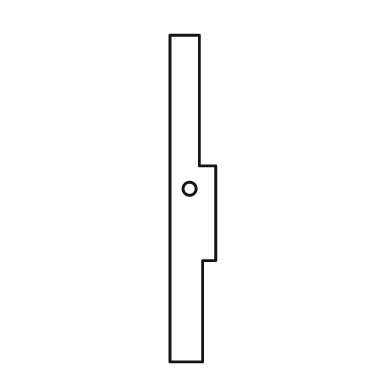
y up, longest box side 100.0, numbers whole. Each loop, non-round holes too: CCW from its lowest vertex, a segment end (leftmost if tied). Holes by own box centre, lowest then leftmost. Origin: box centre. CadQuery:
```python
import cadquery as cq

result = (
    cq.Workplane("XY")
    .moveTo(-7.0, -50.0)
    .lineTo(3.0, -50.0)
    .lineTo(3.0, -19.0)
    .lineTo(7.0, -19.0)
    .lineTo(7.0, 10.0)
    .lineTo(2.0, 10.0)
    .lineTo(2.0, 50.0)
    .lineTo(-7.0, 50.0)
    .close()
    .moveTo(-1.0, 3.0)
    .circle(2.0)
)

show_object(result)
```